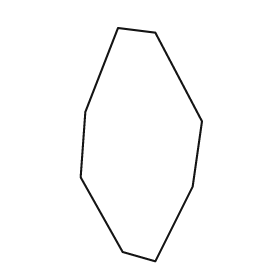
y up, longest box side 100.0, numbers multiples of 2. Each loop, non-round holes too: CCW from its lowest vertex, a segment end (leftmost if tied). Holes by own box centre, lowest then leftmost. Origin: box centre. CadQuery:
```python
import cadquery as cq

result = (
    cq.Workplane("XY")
    .moveTo(6.0, -50.0)
    .lineTo(22.0, -18.0)
    .lineTo(26.0, 10.0)
    .lineTo(6.0, 48.0)
    .lineTo(-10.0, 50.0)
    .lineTo(-24.0, 14.0)
    .lineTo(-26.0, -14.0)
    .lineTo(-8.0, -46.0)
    .close()
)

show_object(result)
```